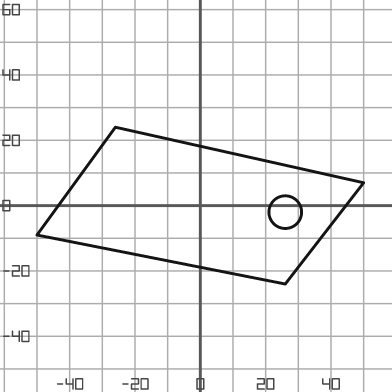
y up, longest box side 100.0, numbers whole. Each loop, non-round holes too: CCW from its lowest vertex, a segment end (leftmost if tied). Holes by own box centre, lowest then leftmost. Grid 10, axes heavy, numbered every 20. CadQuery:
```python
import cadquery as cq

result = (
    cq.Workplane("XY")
    .moveTo(26.0, -24.0)
    .lineTo(50.0, 7.0)
    .lineTo(-26.0, 24.0)
    .lineTo(-50.0, -9.0)
    .close()
    .moveTo(26.0, -2.0)
    .circle(5.0)
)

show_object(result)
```